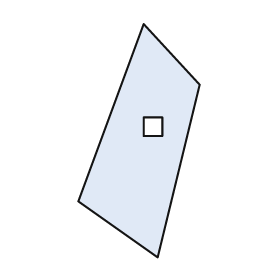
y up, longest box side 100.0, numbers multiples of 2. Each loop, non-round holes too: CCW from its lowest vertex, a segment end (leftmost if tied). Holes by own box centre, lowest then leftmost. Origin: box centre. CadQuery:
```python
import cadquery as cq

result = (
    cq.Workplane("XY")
    .moveTo(8.0, -50.0)
    .lineTo(26.0, 24.0)
    .lineTo(2.0, 50.0)
    .lineTo(-26.0, -26.0)
    .close()
    .moveTo(2.0, 2.0)
    .lineTo(10.0, 2.0)
    .lineTo(10.0, 10.0)
    .lineTo(2.0, 10.0)
    .close()
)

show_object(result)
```